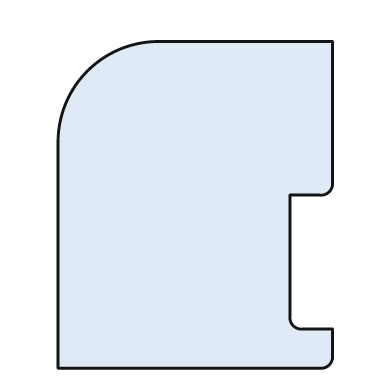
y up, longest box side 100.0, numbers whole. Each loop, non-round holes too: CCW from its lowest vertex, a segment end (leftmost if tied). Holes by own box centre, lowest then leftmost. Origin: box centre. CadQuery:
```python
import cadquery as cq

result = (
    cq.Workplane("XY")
    .moveTo(-42.0, -50.0)
    .lineTo(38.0, -50.0)
    .threePointArc((41.0, -49.0), (42.0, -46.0))
    .lineTo(42.0, -38.0)
    .lineTo(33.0, -38.0)
    .threePointArc((30.0, -37.0), (29.0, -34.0))
    .lineTo(29.0, 3.0)
    .lineTo(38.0, 3.0)
    .threePointArc((41.0, 4.0), (42.0, 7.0))
    .lineTo(42.0, 50.0)
    .lineTo(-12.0, 50.0)
    .threePointArc((-33.0, 41.0), (-42.0, 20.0))
    .close()
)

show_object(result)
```